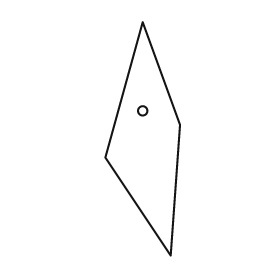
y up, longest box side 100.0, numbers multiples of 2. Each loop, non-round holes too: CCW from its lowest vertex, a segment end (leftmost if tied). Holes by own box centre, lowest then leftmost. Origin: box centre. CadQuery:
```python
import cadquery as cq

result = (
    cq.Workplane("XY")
    .moveTo(12.0, -50.0)
    .lineTo(16.0, 6.0)
    .lineTo(0.0, 50.0)
    .lineTo(-16.0, -8.0)
    .close()
    .moveTo(0.0, 12.0)
    .circle(2.0)
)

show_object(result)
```